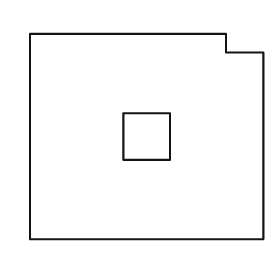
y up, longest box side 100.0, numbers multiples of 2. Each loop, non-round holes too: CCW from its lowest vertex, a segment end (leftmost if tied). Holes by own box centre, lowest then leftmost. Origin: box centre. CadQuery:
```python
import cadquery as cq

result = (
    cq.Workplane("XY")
    .moveTo(-50.0, -44.0)
    .lineTo(50.0, -44.0)
    .lineTo(50.0, 36.0)
    .lineTo(34.0, 36.0)
    .lineTo(34.0, 44.0)
    .lineTo(-50.0, 44.0)
    .close()
    .moveTo(-10.0, -10.0)
    .lineTo(10.0, -10.0)
    .lineTo(10.0, 10.0)
    .lineTo(-10.0, 10.0)
    .close()
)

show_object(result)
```